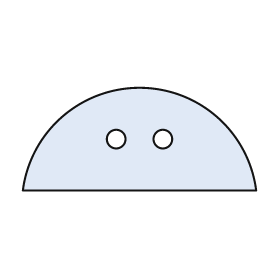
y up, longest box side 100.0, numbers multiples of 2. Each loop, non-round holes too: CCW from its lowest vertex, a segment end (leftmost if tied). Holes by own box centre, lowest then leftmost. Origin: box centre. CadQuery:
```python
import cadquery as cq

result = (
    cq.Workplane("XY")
    .moveTo(-50.0, -22.0)
    .lineTo(50.0, -22.0)
    .threePointArc((0.0, 22.0), (-50.0, -22.0))
    .close()
    .moveTo(-10.0, 0.0)
    .circle(4.0)
    .moveTo(10.0, 0.0)
    .circle(4.0)
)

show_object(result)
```